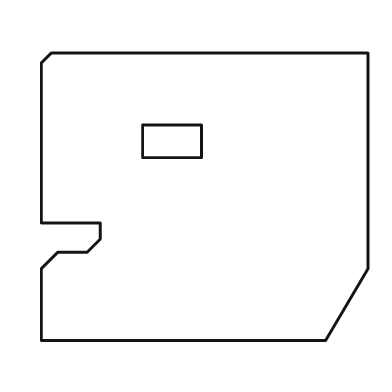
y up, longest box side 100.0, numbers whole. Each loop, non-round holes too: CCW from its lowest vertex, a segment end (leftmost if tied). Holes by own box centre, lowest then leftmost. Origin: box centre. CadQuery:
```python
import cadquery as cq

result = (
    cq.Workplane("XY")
    .moveTo(-50.0, -44.0)
    .lineTo(37.0, -44.0)
    .lineTo(50.0, -22.0)
    .lineTo(50.0, 44.0)
    .lineTo(-47.0, 44.0)
    .lineTo(-50.0, 41.0)
    .lineTo(-50.0, -8.0)
    .lineTo(-32.0, -8.0)
    .lineTo(-32.0, -13.0)
    .lineTo(-36.0, -17.0)
    .lineTo(-45.0, -17.0)
    .lineTo(-50.0, -22.0)
    .close()
    .moveTo(-19.0, 12.0)
    .lineTo(-1.0, 12.0)
    .lineTo(-1.0, 22.0)
    .lineTo(-19.0, 22.0)
    .close()
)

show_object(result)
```